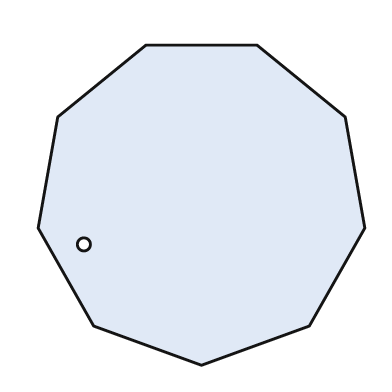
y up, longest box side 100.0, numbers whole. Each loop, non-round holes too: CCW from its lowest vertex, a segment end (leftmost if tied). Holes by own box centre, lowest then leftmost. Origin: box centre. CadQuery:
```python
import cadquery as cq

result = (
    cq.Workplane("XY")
    .moveTo(0.0, -49.0)
    .lineTo(33.0, -37.0)
    .lineTo(50.0, -7.0)
    .lineTo(44.0, 27.0)
    .lineTo(17.0, 49.0)
    .lineTo(-17.0, 49.0)
    .lineTo(-44.0, 27.0)
    .lineTo(-50.0, -7.0)
    .lineTo(-33.0, -37.0)
    .close()
    .moveTo(-36.0, -12.0)
    .circle(2.0)
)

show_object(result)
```